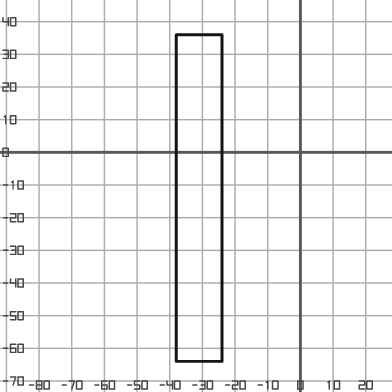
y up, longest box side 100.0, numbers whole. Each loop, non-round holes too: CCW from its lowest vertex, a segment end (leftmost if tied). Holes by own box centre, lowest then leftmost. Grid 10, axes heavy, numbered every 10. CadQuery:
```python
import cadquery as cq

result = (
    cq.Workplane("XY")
    .moveTo(-38.0, -64.0)
    .lineTo(-24.0, -64.0)
    .lineTo(-24.0, 36.0)
    .lineTo(-38.0, 36.0)
    .close()
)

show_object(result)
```